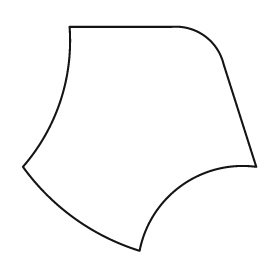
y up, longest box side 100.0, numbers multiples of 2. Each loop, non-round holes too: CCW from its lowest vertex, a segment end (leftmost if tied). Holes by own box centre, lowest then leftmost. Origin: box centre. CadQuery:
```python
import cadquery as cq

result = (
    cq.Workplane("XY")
    .moveTo(0.0, -48.0)
    .threePointArc((18.0, -20.0), (50.0, -12.0))
    .lineTo(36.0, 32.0)
    .threePointArc((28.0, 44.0), (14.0, 48.0))
    .lineTo(-30.0, 48.0)
    .threePointArc((-34.0, 16.0), (-50.0, -12.0))
    .threePointArc((-28.0, -34.0), (0.0, -48.0))
    .close()
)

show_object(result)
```